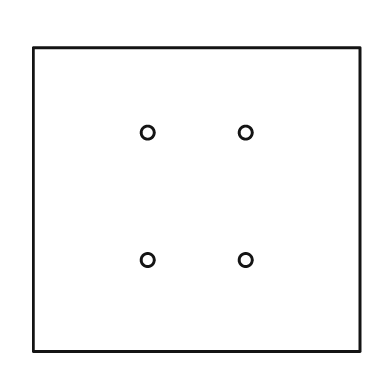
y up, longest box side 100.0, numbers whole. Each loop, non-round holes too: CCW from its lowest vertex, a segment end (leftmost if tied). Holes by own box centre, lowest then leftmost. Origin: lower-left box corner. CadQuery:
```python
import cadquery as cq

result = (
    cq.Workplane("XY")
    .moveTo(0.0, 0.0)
    .lineTo(100.0, 0.0)
    .lineTo(100.0, 93.0)
    .lineTo(0.0, 93.0)
    .close()
    .moveTo(35.0, 28.0)
    .circle(2.0)
    .moveTo(65.0, 28.0)
    .circle(2.0)
    .moveTo(35.0, 67.0)
    .circle(2.0)
    .moveTo(65.0, 67.0)
    .circle(2.0)
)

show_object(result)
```